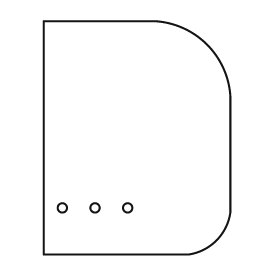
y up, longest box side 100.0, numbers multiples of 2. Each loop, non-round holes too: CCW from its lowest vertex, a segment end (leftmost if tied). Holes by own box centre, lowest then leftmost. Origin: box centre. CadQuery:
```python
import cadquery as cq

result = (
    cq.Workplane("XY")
    .moveTo(-40.0, -50.0)
    .lineTo(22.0, -50.0)
    .threePointArc((34.0, -44.0), (40.0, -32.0))
    .lineTo(40.0, 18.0)
    .threePointArc((30.0, 40.0), (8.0, 50.0))
    .lineTo(-40.0, 50.0)
    .close()
    .moveTo(-32.0, -30.0)
    .circle(2.0)
    .moveTo(-18.0, -30.0)
    .circle(2.0)
    .moveTo(-4.0, -30.0)
    .circle(2.0)
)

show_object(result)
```